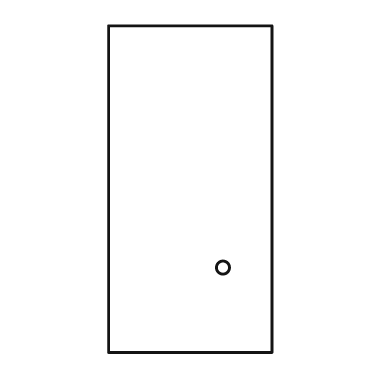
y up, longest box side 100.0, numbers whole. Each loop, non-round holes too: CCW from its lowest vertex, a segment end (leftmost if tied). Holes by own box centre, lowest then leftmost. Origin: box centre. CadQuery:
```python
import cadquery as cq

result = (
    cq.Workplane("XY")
    .moveTo(-25.0, -50.0)
    .lineTo(25.0, -50.0)
    .lineTo(25.0, 50.0)
    .lineTo(-25.0, 50.0)
    .close()
    .moveTo(10.0, -24.0)
    .circle(2.0)
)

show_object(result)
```